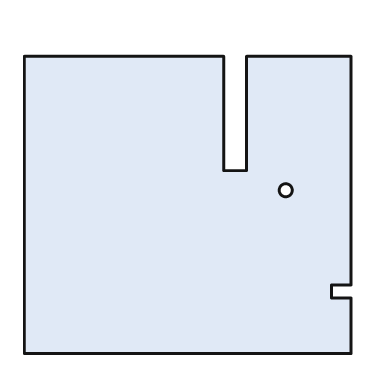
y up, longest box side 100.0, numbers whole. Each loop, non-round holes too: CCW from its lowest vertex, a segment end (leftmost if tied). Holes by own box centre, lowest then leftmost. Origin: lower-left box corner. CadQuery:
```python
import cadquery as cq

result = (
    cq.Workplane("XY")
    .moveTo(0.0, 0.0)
    .lineTo(100.0, 0.0)
    .lineTo(100.0, 17.0)
    .lineTo(94.0, 17.0)
    .lineTo(94.0, 21.0)
    .lineTo(100.0, 21.0)
    .lineTo(100.0, 91.0)
    .lineTo(68.0, 91.0)
    .lineTo(68.0, 56.0)
    .lineTo(61.0, 56.0)
    .lineTo(61.0, 91.0)
    .lineTo(0.0, 91.0)
    .close()
    .moveTo(80.0, 50.0)
    .circle(2.0)
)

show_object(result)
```